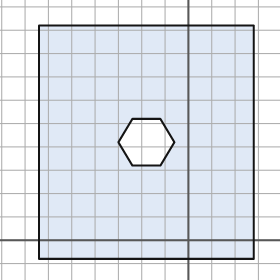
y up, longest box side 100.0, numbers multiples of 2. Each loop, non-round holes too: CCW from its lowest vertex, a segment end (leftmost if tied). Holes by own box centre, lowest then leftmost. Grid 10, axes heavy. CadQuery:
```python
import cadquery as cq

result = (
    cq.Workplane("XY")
    .moveTo(-64.0, -8.0)
    .lineTo(28.0, -8.0)
    .lineTo(28.0, 92.0)
    .lineTo(-64.0, 92.0)
    .close()
    .moveTo(-24.0, 32.0)
    .lineTo(-12.0, 32.0)
    .lineTo(-6.0, 42.0)
    .lineTo(-12.0, 52.0)
    .lineTo(-24.0, 52.0)
    .lineTo(-30.0, 42.0)
    .close()
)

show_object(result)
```